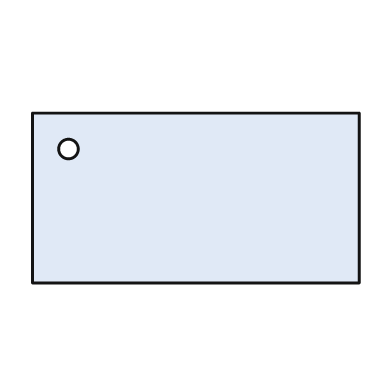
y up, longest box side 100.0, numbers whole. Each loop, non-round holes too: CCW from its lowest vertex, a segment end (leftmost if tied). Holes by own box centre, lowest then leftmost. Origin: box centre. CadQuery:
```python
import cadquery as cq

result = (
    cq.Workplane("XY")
    .moveTo(-50.0, -26.0)
    .lineTo(50.0, -26.0)
    .lineTo(50.0, 26.0)
    .lineTo(-50.0, 26.0)
    .close()
    .moveTo(-39.0, 15.0)
    .circle(3.0)
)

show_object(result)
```